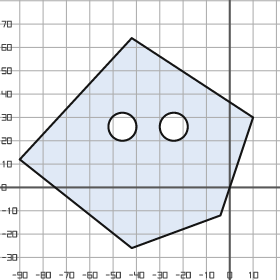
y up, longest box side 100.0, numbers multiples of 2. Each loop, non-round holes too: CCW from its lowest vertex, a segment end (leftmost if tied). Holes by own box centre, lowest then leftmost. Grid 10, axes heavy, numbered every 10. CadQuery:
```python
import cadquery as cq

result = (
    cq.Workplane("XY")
    .moveTo(-42.0, -26.0)
    .lineTo(-4.0, -12.0)
    .lineTo(10.0, 30.0)
    .lineTo(-42.0, 64.0)
    .lineTo(-90.0, 12.0)
    .close()
    .moveTo(-46.0, 26.0)
    .circle(6.0)
    .moveTo(-24.0, 26.0)
    .circle(6.0)
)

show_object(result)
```